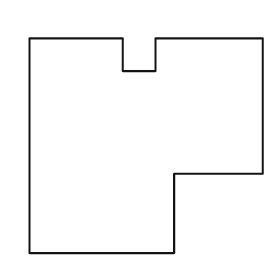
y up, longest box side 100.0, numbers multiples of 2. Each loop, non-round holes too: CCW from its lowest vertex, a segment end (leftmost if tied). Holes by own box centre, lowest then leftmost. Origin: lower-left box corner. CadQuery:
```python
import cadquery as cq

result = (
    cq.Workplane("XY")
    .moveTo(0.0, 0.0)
    .lineTo(62.0, 0.0)
    .lineTo(62.0, 34.0)
    .lineTo(100.0, 34.0)
    .lineTo(100.0, 92.0)
    .lineTo(54.0, 92.0)
    .lineTo(54.0, 78.0)
    .lineTo(40.0, 78.0)
    .lineTo(40.0, 92.0)
    .lineTo(0.0, 92.0)
    .close()
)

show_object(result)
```